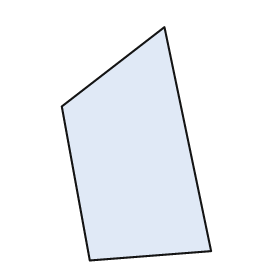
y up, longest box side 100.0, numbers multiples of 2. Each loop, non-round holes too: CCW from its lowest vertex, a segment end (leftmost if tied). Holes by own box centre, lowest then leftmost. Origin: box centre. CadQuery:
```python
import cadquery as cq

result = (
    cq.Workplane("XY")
    .moveTo(-20.0, -50.0)
    .lineTo(32.0, -46.0)
    .lineTo(12.0, 50.0)
    .lineTo(-32.0, 16.0)
    .close()
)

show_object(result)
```